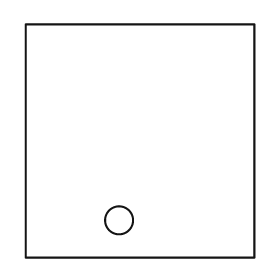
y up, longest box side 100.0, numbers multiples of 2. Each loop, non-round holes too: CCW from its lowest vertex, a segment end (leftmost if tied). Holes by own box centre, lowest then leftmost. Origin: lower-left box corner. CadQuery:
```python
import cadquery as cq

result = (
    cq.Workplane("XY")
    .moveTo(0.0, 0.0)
    .lineTo(98.0, 0.0)
    .lineTo(98.0, 100.0)
    .lineTo(0.0, 100.0)
    .close()
    .moveTo(40.0, 16.0)
    .circle(6.0)
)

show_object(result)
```